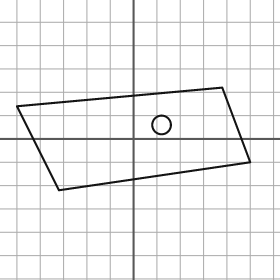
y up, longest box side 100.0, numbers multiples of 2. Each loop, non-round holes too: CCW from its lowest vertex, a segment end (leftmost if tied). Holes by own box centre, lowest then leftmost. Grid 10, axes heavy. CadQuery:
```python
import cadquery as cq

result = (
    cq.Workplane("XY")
    .moveTo(-32.0, -22.0)
    .lineTo(50.0, -10.0)
    .lineTo(38.0, 22.0)
    .lineTo(-50.0, 14.0)
    .close()
    .moveTo(12.0, 6.0)
    .circle(4.0)
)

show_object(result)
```